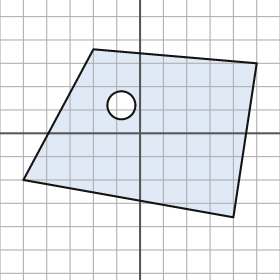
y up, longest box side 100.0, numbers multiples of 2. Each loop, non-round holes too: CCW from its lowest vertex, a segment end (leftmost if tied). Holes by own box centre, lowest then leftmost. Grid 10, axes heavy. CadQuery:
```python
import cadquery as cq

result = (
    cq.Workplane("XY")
    .moveTo(40.0, -36.0)
    .lineTo(50.0, 30.0)
    .lineTo(-20.0, 36.0)
    .lineTo(-50.0, -20.0)
    .close()
    .moveTo(-8.0, 12.0)
    .circle(6.0)
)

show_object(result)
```